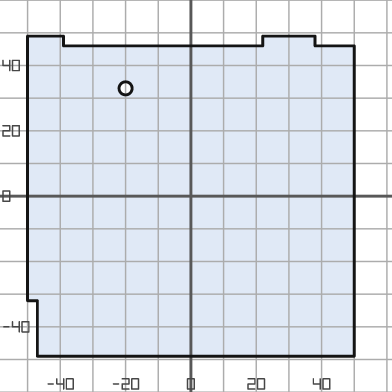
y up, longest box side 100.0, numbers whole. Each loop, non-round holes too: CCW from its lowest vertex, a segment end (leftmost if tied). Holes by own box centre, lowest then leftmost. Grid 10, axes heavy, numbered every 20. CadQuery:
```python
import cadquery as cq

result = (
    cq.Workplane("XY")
    .moveTo(-47.0, -49.0)
    .lineTo(50.0, -49.0)
    .lineTo(50.0, 46.0)
    .lineTo(38.0, 46.0)
    .lineTo(38.0, 49.0)
    .lineTo(22.0, 49.0)
    .lineTo(22.0, 46.0)
    .lineTo(-39.0, 46.0)
    .lineTo(-39.0, 49.0)
    .lineTo(-50.0, 49.0)
    .lineTo(-50.0, -32.0)
    .lineTo(-47.0, -32.0)
    .close()
    .moveTo(-20.0, 33.0)
    .circle(2.0)
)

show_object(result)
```